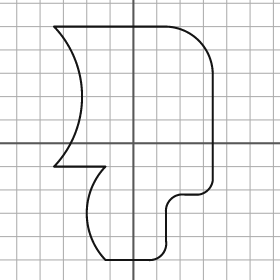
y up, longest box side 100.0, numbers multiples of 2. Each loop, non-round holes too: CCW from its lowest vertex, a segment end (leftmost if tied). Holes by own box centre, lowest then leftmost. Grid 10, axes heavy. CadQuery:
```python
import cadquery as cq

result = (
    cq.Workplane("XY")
    .moveTo(-12.0, -50.0)
    .lineTo(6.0, -50.0)
    .threePointArc((12.0, -48.0), (14.0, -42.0))
    .lineTo(14.0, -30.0)
    .threePointArc((16.0, -24.0), (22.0, -22.0))
    .lineTo(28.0, -22.0)
    .threePointArc((32.0, -20.0), (34.0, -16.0))
    .lineTo(34.0, 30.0)
    .threePointArc((28.0, 44.0), (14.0, 50.0))
    .lineTo(-34.0, 50.0)
    .threePointArc((-22.0, 20.0), (-34.0, -10.0))
    .lineTo(-12.0, -10.0)
    .threePointArc((-20.0, -30.0), (-12.0, -50.0))
    .close()
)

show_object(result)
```